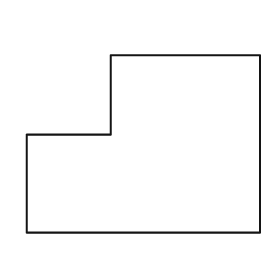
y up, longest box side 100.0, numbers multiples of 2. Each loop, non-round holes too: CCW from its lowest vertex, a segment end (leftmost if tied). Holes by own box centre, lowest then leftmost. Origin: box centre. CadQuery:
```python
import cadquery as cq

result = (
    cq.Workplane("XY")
    .moveTo(-50.0, -38.0)
    .lineTo(50.0, -38.0)
    .lineTo(50.0, 38.0)
    .lineTo(-14.0, 38.0)
    .lineTo(-14.0, 4.0)
    .lineTo(-50.0, 4.0)
    .close()
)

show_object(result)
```